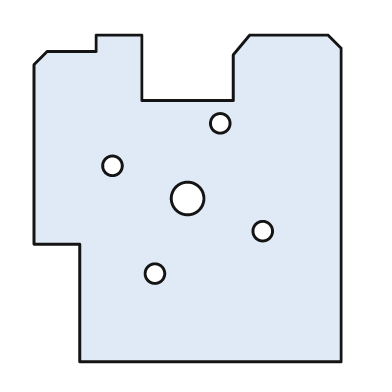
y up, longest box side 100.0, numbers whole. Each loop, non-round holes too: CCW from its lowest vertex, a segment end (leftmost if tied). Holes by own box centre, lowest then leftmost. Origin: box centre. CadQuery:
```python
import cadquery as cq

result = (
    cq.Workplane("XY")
    .moveTo(-33.0, -50.0)
    .lineTo(47.0, -50.0)
    .lineTo(47.0, 46.0)
    .lineTo(43.0, 50.0)
    .lineTo(19.0, 50.0)
    .lineTo(14.0, 44.0)
    .lineTo(14.0, 30.0)
    .lineTo(-14.0, 30.0)
    .lineTo(-14.0, 50.0)
    .lineTo(-28.0, 50.0)
    .lineTo(-28.0, 45.0)
    .lineTo(-43.0, 45.0)
    .lineTo(-47.0, 41.0)
    .lineTo(-47.0, -14.0)
    .lineTo(-33.0, -14.0)
    .close()
    .moveTo(-10.0, -23.0)
    .circle(3.0)
    .moveTo(23.0, -10.0)
    .circle(3.0)
    .moveTo(0.0, 0.0)
    .circle(5.0)
    .moveTo(-23.0, 10.0)
    .circle(3.0)
    .moveTo(10.0, 23.0)
    .circle(3.0)
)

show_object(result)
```